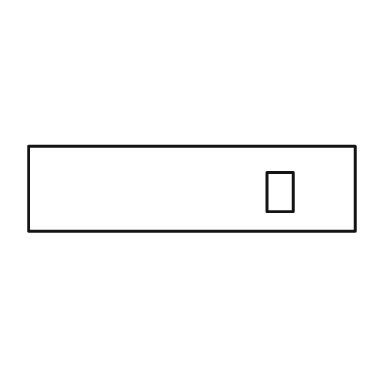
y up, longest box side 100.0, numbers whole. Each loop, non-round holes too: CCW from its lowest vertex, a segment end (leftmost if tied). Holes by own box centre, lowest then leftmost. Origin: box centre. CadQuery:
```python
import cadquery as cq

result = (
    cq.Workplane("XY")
    .moveTo(-50.0, -13.0)
    .lineTo(50.0, -13.0)
    .lineTo(50.0, 13.0)
    .lineTo(-50.0, 13.0)
    .close()
    .moveTo(23.0, -7.0)
    .lineTo(31.0, -7.0)
    .lineTo(31.0, 5.0)
    .lineTo(23.0, 5.0)
    .close()
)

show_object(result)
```